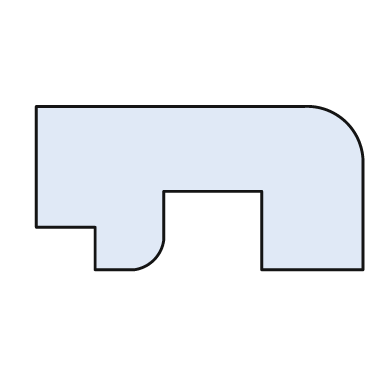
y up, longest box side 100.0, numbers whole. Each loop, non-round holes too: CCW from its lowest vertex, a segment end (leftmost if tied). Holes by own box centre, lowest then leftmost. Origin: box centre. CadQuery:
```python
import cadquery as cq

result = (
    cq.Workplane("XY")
    .moveTo(-32.0, -25.0)
    .lineTo(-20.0, -25.0)
    .threePointArc((-14.0, -22.0), (-11.0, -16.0))
    .lineTo(-11.0, -1.0)
    .lineTo(19.0, -1.0)
    .lineTo(19.0, -25.0)
    .lineTo(50.0, -25.0)
    .lineTo(50.0, 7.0)
    .threePointArc((45.0, 20.0), (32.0, 25.0))
    .lineTo(-50.0, 25.0)
    .lineTo(-50.0, -12.0)
    .lineTo(-32.0, -12.0)
    .close()
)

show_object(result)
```